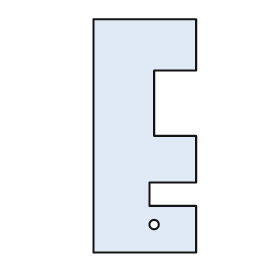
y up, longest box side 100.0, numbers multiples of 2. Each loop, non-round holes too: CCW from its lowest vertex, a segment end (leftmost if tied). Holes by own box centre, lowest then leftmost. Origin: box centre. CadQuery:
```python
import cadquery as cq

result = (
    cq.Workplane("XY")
    .moveTo(-22.0, -50.0)
    .lineTo(22.0, -50.0)
    .lineTo(22.0, -30.0)
    .lineTo(2.0, -30.0)
    .lineTo(2.0, -20.0)
    .lineTo(22.0, -20.0)
    .lineTo(22.0, 0.0)
    .lineTo(4.0, 0.0)
    .lineTo(4.0, 28.0)
    .lineTo(22.0, 28.0)
    .lineTo(22.0, 50.0)
    .lineTo(-22.0, 50.0)
    .close()
    .moveTo(4.0, -38.0)
    .circle(2.0)
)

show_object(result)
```